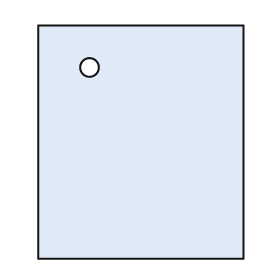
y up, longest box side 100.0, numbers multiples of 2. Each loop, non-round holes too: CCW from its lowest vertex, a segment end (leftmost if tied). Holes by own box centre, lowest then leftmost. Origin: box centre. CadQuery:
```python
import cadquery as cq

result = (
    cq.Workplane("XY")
    .moveTo(-44.0, -50.0)
    .lineTo(44.0, -50.0)
    .lineTo(44.0, 50.0)
    .lineTo(-44.0, 50.0)
    .close()
    .moveTo(-22.0, 32.0)
    .circle(4.0)
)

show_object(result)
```